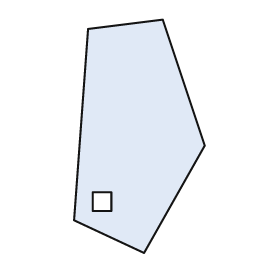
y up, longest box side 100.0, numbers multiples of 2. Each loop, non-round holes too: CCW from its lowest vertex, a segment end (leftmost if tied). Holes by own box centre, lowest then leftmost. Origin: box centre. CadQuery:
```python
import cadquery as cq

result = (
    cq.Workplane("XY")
    .moveTo(2.0, -50.0)
    .lineTo(28.0, -4.0)
    .lineTo(10.0, 50.0)
    .lineTo(-22.0, 46.0)
    .lineTo(-28.0, -36.0)
    .close()
    .moveTo(-20.0, -32.0)
    .lineTo(-12.0, -32.0)
    .lineTo(-12.0, -24.0)
    .lineTo(-20.0, -24.0)
    .close()
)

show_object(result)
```